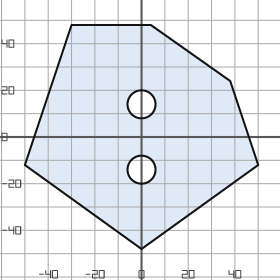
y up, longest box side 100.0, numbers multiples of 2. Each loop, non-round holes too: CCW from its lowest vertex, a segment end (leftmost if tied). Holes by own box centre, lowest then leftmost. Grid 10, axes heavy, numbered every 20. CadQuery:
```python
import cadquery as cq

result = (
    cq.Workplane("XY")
    .moveTo(0.0, -48.0)
    .lineTo(50.0, -12.0)
    .lineTo(38.0, 24.0)
    .lineTo(4.0, 48.0)
    .lineTo(-30.0, 48.0)
    .lineTo(-50.0, -12.0)
    .close()
    .moveTo(0.0, -14.0)
    .circle(6.0)
    .moveTo(0.0, 14.0)
    .circle(6.0)
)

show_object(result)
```